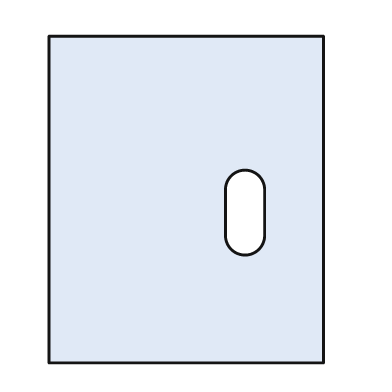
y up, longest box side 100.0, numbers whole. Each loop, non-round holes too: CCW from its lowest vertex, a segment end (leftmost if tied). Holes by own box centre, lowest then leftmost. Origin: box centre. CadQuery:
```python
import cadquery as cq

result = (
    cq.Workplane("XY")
    .moveTo(-42.0, -50.0)
    .lineTo(42.0, -50.0)
    .lineTo(42.0, 50.0)
    .lineTo(-42.0, 50.0)
    .close()
    .moveTo(12.0, -11.0)
    .threePointArc((18.0, -17.0), (24.0, -11.0))
    .lineTo(24.0, 3.0)
    .threePointArc((18.0, 9.0), (12.0, 3.0))
    .close()
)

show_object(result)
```